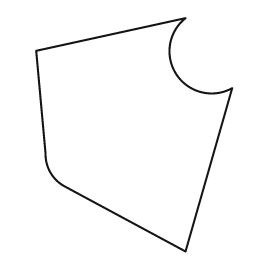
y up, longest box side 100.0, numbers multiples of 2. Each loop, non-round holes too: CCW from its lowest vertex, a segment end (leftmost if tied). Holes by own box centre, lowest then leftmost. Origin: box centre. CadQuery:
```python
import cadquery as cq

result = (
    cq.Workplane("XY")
    .moveTo(22.0, -50.0)
    .lineTo(42.0, 20.0)
    .threePointArc((18.0, 26.0), (22.0, 50.0))
    .lineTo(-42.0, 36.0)
    .lineTo(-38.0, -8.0)
    .threePointArc((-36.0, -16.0), (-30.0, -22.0))
    .close()
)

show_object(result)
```